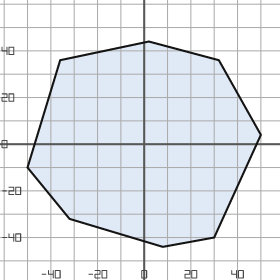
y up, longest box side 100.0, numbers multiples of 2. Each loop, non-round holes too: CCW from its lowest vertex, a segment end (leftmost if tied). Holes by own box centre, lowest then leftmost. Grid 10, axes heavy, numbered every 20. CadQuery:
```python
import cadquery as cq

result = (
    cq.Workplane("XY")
    .moveTo(8.0, -44.0)
    .lineTo(30.0, -40.0)
    .lineTo(50.0, 4.0)
    .lineTo(32.0, 36.0)
    .lineTo(2.0, 44.0)
    .lineTo(-36.0, 36.0)
    .lineTo(-50.0, -10.0)
    .lineTo(-32.0, -32.0)
    .close()
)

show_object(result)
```